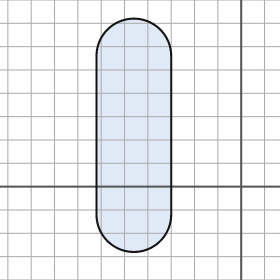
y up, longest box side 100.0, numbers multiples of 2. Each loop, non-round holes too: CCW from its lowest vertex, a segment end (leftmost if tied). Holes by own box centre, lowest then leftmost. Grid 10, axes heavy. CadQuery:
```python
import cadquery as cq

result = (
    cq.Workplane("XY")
    .moveTo(-62.0, -12.0)
    .threePointArc((-46.0, -28.0), (-30.0, -12.0))
    .lineTo(-30.0, 56.0)
    .threePointArc((-46.0, 72.0), (-62.0, 56.0))
    .close()
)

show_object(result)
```